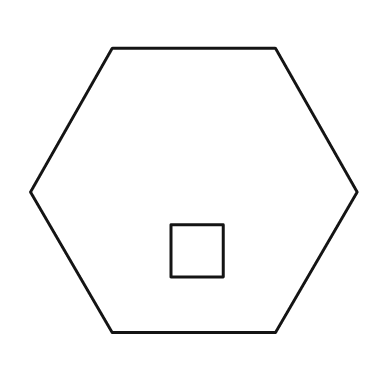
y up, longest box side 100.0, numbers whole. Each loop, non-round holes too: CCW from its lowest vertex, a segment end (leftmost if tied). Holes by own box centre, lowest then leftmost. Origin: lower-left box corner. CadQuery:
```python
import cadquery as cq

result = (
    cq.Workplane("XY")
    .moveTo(25.0, 0.0)
    .lineTo(75.0, 0.0)
    .lineTo(100.0, 43.0)
    .lineTo(75.0, 87.0)
    .lineTo(25.0, 87.0)
    .lineTo(0.0, 43.0)
    .close()
    .moveTo(43.0, 17.0)
    .lineTo(59.0, 17.0)
    .lineTo(59.0, 33.0)
    .lineTo(43.0, 33.0)
    .close()
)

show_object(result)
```